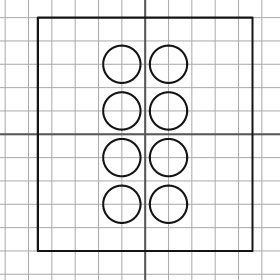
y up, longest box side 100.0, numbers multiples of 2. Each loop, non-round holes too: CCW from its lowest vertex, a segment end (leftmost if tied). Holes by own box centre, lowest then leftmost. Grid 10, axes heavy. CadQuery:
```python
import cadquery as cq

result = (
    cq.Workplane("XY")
    .moveTo(-46.0, -50.0)
    .lineTo(46.0, -50.0)
    .lineTo(46.0, 50.0)
    .lineTo(-46.0, 50.0)
    .close()
    .moveTo(-10.0, -30.0)
    .circle(8.0)
    .moveTo(10.0, -30.0)
    .circle(8.0)
    .moveTo(-10.0, -10.0)
    .circle(8.0)
    .moveTo(10.0, -10.0)
    .circle(8.0)
    .moveTo(-10.0, 10.0)
    .circle(8.0)
    .moveTo(10.0, 10.0)
    .circle(8.0)
    .moveTo(-10.0, 30.0)
    .circle(8.0)
    .moveTo(10.0, 30.0)
    .circle(8.0)
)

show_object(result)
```